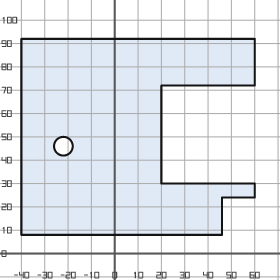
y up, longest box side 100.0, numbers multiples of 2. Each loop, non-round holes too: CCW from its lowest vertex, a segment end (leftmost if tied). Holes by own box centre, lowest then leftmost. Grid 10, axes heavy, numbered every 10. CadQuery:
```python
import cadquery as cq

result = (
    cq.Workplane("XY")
    .moveTo(-40.0, 8.0)
    .lineTo(46.0, 8.0)
    .lineTo(46.0, 24.0)
    .lineTo(60.0, 24.0)
    .lineTo(60.0, 30.0)
    .lineTo(20.0, 30.0)
    .lineTo(20.0, 72.0)
    .lineTo(60.0, 72.0)
    .lineTo(60.0, 92.0)
    .lineTo(-40.0, 92.0)
    .close()
    .moveTo(-22.0, 46.0)
    .circle(4.0)
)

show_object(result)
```